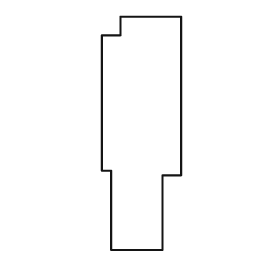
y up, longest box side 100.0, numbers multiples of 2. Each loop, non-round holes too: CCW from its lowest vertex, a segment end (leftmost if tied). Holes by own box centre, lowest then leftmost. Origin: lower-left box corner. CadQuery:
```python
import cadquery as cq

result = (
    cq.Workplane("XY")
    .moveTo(4.0, 0.0)
    .lineTo(26.0, 0.0)
    .lineTo(26.0, 32.0)
    .lineTo(34.0, 32.0)
    .lineTo(34.0, 100.0)
    .lineTo(8.0, 100.0)
    .lineTo(8.0, 92.0)
    .lineTo(0.0, 92.0)
    .lineTo(0.0, 34.0)
    .lineTo(4.0, 34.0)
    .close()
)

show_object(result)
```